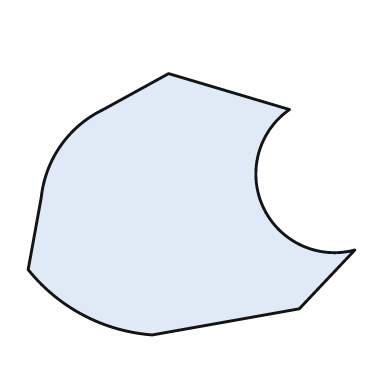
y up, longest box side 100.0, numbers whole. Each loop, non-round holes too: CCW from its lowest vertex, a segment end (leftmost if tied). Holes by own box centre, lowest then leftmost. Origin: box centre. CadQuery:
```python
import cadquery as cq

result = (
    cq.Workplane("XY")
    .moveTo(-12.0, -40.0)
    .lineTo(33.0, -32.0)
    .lineTo(50.0, -14.0)
    .threePointArc((22.0, -1.0), (30.0, 29.0))
    .lineTo(-7.0, 40.0)
    .lineTo(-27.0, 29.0)
    .threePointArc((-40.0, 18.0), (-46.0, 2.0))
    .lineTo(-50.0, -20.0)
    .threePointArc((-33.0, -34.0), (-12.0, -40.0))
    .close()
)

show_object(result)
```